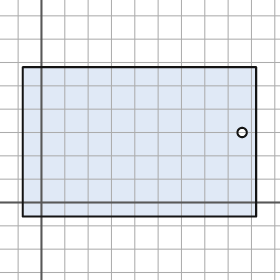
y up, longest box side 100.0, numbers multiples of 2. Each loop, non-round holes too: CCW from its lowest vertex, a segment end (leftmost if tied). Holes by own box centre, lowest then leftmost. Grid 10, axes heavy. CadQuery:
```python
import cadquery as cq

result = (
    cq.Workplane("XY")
    .moveTo(-8.0, -6.0)
    .lineTo(92.0, -6.0)
    .lineTo(92.0, 58.0)
    .lineTo(-8.0, 58.0)
    .close()
    .moveTo(86.0, 30.0)
    .circle(2.0)
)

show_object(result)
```